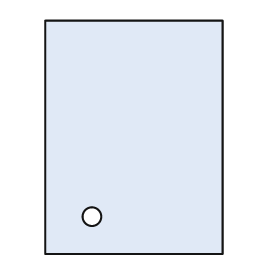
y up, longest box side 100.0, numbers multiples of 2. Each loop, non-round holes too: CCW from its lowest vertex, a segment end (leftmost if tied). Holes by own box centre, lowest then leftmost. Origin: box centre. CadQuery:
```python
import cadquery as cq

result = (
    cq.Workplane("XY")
    .moveTo(-38.0, -50.0)
    .lineTo(38.0, -50.0)
    .lineTo(38.0, 50.0)
    .lineTo(-38.0, 50.0)
    .close()
    .moveTo(-18.0, -34.0)
    .circle(4.0)
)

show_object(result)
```